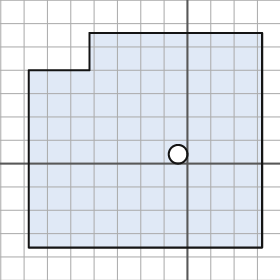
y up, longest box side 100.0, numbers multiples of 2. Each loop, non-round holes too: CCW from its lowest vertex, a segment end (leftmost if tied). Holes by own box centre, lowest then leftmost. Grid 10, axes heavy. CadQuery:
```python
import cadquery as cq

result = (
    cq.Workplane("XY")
    .moveTo(-68.0, -36.0)
    .lineTo(32.0, -36.0)
    .lineTo(32.0, 56.0)
    .lineTo(-42.0, 56.0)
    .lineTo(-42.0, 40.0)
    .lineTo(-68.0, 40.0)
    .close()
    .moveTo(-4.0, 4.0)
    .circle(4.0)
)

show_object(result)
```